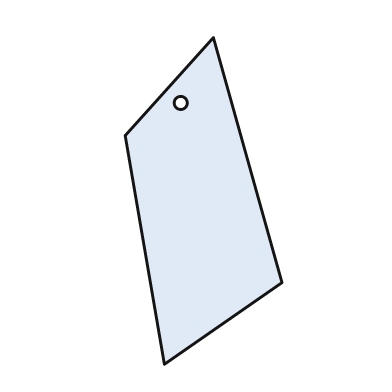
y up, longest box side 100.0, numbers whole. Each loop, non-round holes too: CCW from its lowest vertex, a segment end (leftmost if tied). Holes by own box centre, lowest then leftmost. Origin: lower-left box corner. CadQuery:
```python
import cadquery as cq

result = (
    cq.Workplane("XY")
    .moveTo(12.0, 0.0)
    .lineTo(48.0, 25.0)
    .lineTo(27.0, 100.0)
    .lineTo(0.0, 70.0)
    .close()
    .moveTo(17.0, 80.0)
    .circle(2.0)
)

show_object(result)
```